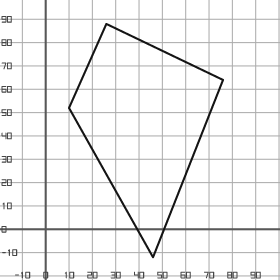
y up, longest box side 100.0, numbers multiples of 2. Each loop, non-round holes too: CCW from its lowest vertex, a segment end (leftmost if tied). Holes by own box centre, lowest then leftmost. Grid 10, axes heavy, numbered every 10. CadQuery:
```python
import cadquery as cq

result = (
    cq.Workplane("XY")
    .moveTo(46.0, -12.0)
    .lineTo(76.0, 64.0)
    .lineTo(26.0, 88.0)
    .lineTo(10.0, 52.0)
    .close()
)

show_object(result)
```